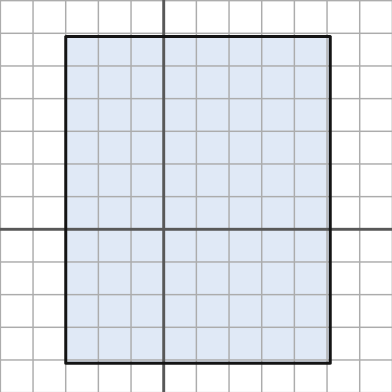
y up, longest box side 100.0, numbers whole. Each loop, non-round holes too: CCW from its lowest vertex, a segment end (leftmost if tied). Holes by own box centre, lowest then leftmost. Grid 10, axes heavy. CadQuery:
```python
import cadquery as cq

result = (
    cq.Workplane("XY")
    .moveTo(-30.0, -41.0)
    .lineTo(51.0, -41.0)
    .lineTo(51.0, 59.0)
    .lineTo(-30.0, 59.0)
    .close()
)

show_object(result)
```